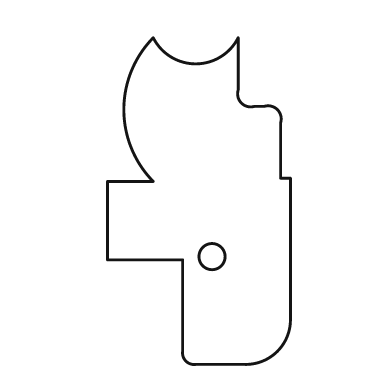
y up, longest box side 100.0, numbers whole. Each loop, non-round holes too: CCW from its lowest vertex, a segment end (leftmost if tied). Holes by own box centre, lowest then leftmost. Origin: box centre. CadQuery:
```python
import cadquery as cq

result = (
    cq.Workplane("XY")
    .moveTo(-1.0, -50.0)
    .lineTo(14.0, -50.0)
    .threePointArc((24.0, -46.0), (28.0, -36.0))
    .lineTo(28.0, 7.0)
    .lineTo(25.0, 7.0)
    .lineTo(25.0, 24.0)
    .threePointArc((24.0, 28.0), (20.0, 29.0))
    .lineTo(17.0, 29.0)
    .threePointArc((13.0, 30.0), (12.0, 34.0))
    .lineTo(12.0, 50.0)
    .threePointArc((-1.0, 42.0), (-14.0, 50.0))
    .threePointArc((-23.0, 28.0), (-14.0, 6.0))
    .lineTo(-28.0, 6.0)
    .lineTo(-28.0, -18.0)
    .lineTo(-5.0, -18.0)
    .lineTo(-5.0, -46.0)
    .threePointArc((-4.0, -49.0), (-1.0, -50.0))
    .close()
    .moveTo(4.0, -17.0)
    .circle(4.0)
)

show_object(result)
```